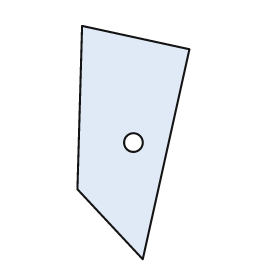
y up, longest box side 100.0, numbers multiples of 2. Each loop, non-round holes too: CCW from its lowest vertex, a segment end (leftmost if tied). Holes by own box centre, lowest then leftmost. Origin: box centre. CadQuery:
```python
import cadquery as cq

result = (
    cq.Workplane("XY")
    .moveTo(4.0, -50.0)
    .lineTo(24.0, 40.0)
    .lineTo(-22.0, 50.0)
    .lineTo(-24.0, -20.0)
    .close()
    .moveTo(0.0, 0.0)
    .circle(4.0)
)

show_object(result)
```